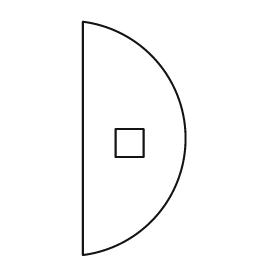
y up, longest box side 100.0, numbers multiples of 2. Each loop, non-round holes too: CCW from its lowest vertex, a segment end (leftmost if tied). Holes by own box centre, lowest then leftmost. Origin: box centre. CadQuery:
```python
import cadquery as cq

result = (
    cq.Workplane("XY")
    .moveTo(-22.0, -50.0)
    .threePointArc((22.0, 0.0), (-22.0, 50.0))
    .close()
    .moveTo(-8.0, -8.0)
    .lineTo(4.0, -8.0)
    .lineTo(4.0, 4.0)
    .lineTo(-8.0, 4.0)
    .close()
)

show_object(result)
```